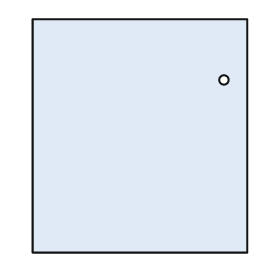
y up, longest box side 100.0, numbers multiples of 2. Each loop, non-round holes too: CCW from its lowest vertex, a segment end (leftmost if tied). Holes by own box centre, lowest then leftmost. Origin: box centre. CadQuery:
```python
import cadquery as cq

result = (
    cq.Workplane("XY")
    .moveTo(-46.0, -50.0)
    .lineTo(46.0, -50.0)
    .lineTo(46.0, 50.0)
    .lineTo(-46.0, 50.0)
    .close()
    .moveTo(36.0, 24.0)
    .circle(2.0)
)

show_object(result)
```